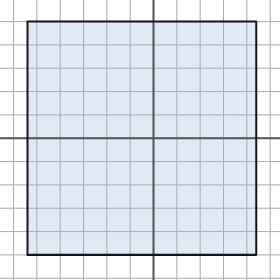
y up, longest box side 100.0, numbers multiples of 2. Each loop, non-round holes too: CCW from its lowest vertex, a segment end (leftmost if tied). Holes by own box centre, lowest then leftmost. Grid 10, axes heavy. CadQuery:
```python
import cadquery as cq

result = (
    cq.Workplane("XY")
    .moveTo(-54.0, -50.0)
    .lineTo(44.0, -50.0)
    .lineTo(44.0, 50.0)
    .lineTo(-54.0, 50.0)
    .close()
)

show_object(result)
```